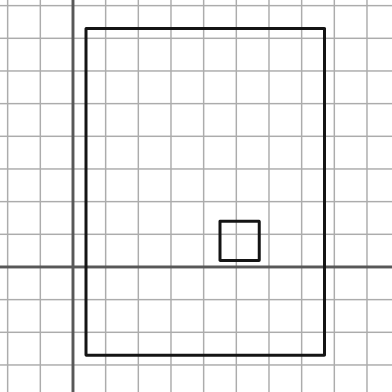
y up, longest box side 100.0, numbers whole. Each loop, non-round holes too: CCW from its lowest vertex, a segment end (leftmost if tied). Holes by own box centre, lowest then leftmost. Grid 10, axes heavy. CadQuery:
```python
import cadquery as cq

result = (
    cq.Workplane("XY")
    .moveTo(4.0, -27.0)
    .lineTo(77.0, -27.0)
    .lineTo(77.0, 73.0)
    .lineTo(4.0, 73.0)
    .close()
    .moveTo(45.0, 2.0)
    .lineTo(57.0, 2.0)
    .lineTo(57.0, 14.0)
    .lineTo(45.0, 14.0)
    .close()
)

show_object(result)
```